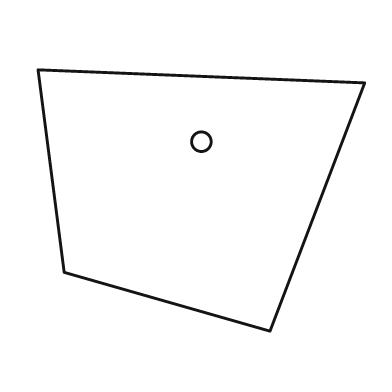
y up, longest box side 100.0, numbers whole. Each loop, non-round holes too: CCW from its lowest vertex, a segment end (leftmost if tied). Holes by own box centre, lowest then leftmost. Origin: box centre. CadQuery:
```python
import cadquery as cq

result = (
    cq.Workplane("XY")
    .moveTo(21.0, -40.0)
    .lineTo(50.0, 36.0)
    .lineTo(-50.0, 40.0)
    .lineTo(-42.0, -22.0)
    .close()
    .moveTo(0.0, 18.0)
    .circle(3.0)
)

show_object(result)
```